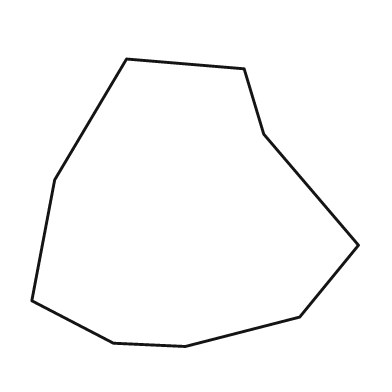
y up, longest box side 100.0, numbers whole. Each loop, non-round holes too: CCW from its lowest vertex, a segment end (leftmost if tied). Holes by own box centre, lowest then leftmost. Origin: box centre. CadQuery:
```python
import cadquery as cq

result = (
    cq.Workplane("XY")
    .moveTo(-3.0, -44.0)
    .lineTo(32.0, -35.0)
    .lineTo(50.0, -13.0)
    .lineTo(21.0, 21.0)
    .lineTo(15.0, 41.0)
    .lineTo(-21.0, 44.0)
    .lineTo(-43.0, 7.0)
    .lineTo(-50.0, -30.0)
    .lineTo(-25.0, -43.0)
    .close()
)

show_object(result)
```